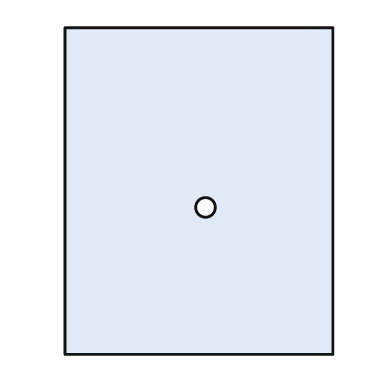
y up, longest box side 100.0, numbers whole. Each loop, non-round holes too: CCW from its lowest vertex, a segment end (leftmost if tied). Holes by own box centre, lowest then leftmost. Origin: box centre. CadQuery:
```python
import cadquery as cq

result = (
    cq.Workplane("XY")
    .moveTo(-41.0, -50.0)
    .lineTo(41.0, -50.0)
    .lineTo(41.0, 50.0)
    .lineTo(-41.0, 50.0)
    .close()
    .moveTo(2.0, -5.0)
    .circle(3.0)
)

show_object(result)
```